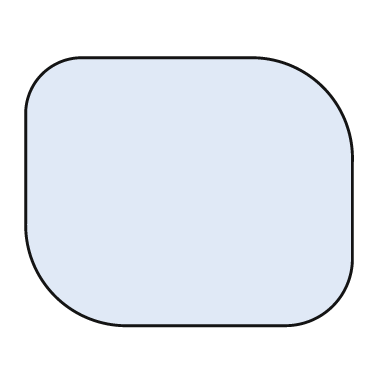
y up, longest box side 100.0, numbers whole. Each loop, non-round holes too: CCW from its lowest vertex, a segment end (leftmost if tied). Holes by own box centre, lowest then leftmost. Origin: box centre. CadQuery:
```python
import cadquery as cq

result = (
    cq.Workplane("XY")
    .moveTo(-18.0, -41.0)
    .lineTo(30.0, -41.0)
    .threePointArc((44.0, -35.0), (50.0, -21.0))
    .lineTo(50.0, 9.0)
    .threePointArc((41.0, 32.0), (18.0, 41.0))
    .lineTo(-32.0, 41.0)
    .threePointArc((-45.0, 36.0), (-50.0, 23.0))
    .lineTo(-50.0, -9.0)
    .threePointArc((-41.0, -32.0), (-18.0, -41.0))
    .close()
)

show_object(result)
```